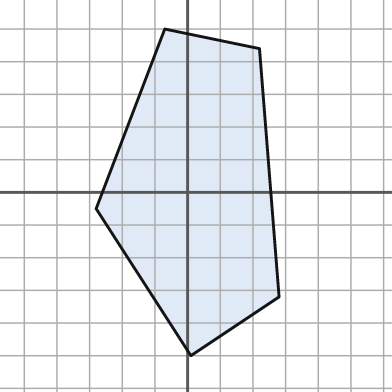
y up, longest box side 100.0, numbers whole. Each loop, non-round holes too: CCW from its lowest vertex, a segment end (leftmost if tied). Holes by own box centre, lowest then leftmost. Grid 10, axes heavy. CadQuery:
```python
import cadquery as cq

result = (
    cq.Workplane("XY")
    .moveTo(1.0, -50.0)
    .lineTo(28.0, -32.0)
    .lineTo(22.0, 44.0)
    .lineTo(-7.0, 50.0)
    .lineTo(-28.0, -5.0)
    .close()
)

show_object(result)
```